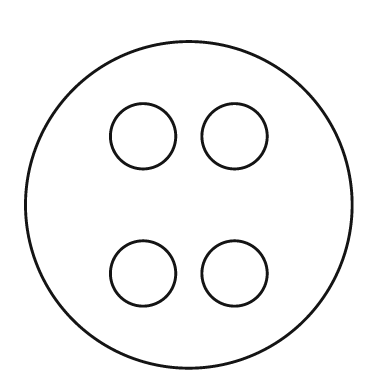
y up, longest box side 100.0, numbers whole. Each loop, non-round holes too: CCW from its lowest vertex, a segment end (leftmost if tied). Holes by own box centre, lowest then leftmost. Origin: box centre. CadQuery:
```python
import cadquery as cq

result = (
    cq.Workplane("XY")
    .moveTo(0.0, 0.0)
    .circle(50.0)
    .moveTo(-14.0, -21.0)
    .circle(10.0)
    .moveTo(14.0, -21.0)
    .circle(10.0)
    .moveTo(-14.0, 21.0)
    .circle(10.0)
    .moveTo(14.0, 21.0)
    .circle(10.0)
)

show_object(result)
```